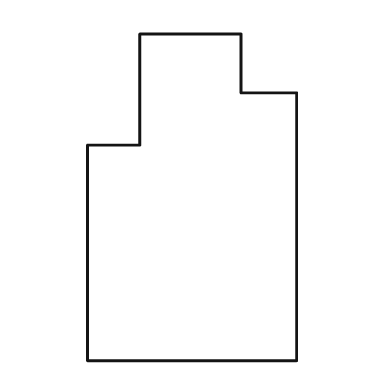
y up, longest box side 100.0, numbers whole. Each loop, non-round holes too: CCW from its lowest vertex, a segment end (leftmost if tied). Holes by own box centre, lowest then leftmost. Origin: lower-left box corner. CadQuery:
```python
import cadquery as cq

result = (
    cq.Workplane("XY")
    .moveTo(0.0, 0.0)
    .lineTo(64.0, 0.0)
    .lineTo(64.0, 82.0)
    .lineTo(47.0, 82.0)
    .lineTo(47.0, 100.0)
    .lineTo(16.0, 100.0)
    .lineTo(16.0, 66.0)
    .lineTo(0.0, 66.0)
    .close()
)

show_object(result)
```